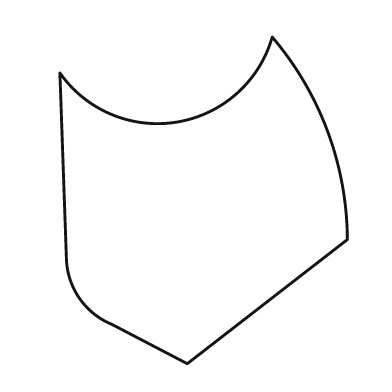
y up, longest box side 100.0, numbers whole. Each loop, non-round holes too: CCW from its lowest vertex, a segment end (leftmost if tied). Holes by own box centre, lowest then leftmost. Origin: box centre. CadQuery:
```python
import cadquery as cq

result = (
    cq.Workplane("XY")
    .moveTo(-5.0, -50.0)
    .lineTo(44.0, -12.0)
    .threePointArc((38.0, 21.0), (21.0, 50.0))
    .threePointArc((-8.0, 24.0), (-44.0, 39.0))
    .lineTo(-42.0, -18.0)
    .threePointArc((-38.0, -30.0), (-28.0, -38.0))
    .close()
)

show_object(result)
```